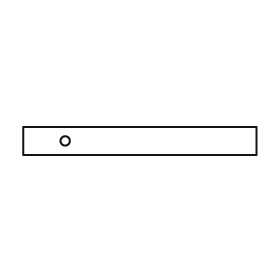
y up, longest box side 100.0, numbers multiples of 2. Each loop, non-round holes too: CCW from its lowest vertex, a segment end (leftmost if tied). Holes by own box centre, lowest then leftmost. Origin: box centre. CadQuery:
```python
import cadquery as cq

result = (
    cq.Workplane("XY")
    .moveTo(-50.0, -6.0)
    .lineTo(50.0, -6.0)
    .lineTo(50.0, 6.0)
    .lineTo(-50.0, 6.0)
    .close()
    .moveTo(-32.0, 0.0)
    .circle(2.0)
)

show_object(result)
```